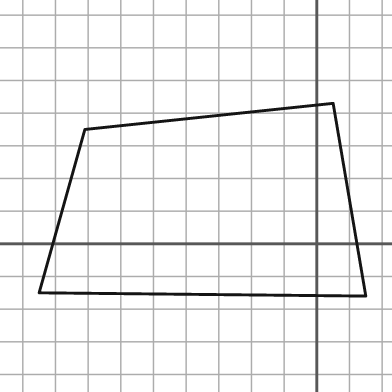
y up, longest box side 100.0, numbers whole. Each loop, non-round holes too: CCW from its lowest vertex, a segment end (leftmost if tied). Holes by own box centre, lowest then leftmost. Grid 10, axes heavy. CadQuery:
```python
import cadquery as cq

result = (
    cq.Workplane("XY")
    .moveTo(15.0, -16.0)
    .lineTo(5.0, 43.0)
    .lineTo(-71.0, 35.0)
    .lineTo(-85.0, -15.0)
    .close()
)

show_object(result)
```